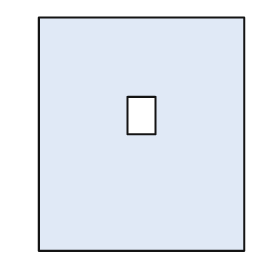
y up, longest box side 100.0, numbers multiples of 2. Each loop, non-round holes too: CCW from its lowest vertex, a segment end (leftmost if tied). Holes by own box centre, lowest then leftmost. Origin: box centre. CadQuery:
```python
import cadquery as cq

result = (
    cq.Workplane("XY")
    .moveTo(-44.0, -50.0)
    .lineTo(44.0, -50.0)
    .lineTo(44.0, 50.0)
    .lineTo(-44.0, 50.0)
    .close()
    .moveTo(-6.0, 0.0)
    .lineTo(6.0, 0.0)
    .lineTo(6.0, 16.0)
    .lineTo(-6.0, 16.0)
    .close()
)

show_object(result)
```